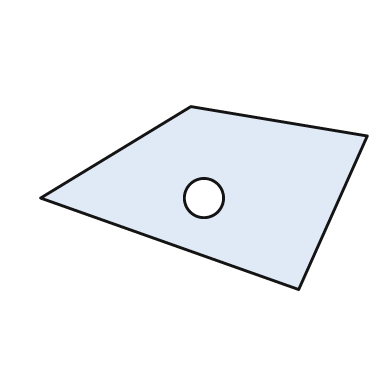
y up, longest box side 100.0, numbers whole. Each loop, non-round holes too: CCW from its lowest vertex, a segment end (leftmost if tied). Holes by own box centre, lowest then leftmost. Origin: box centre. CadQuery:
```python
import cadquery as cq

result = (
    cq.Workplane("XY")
    .moveTo(29.0, -28.0)
    .lineTo(50.0, 19.0)
    .lineTo(-4.0, 28.0)
    .lineTo(-50.0, 0.0)
    .close()
    .moveTo(0.0, 0.0)
    .circle(6.0)
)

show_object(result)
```